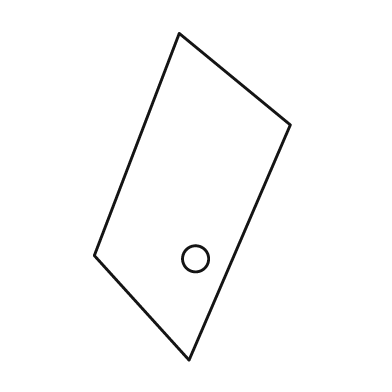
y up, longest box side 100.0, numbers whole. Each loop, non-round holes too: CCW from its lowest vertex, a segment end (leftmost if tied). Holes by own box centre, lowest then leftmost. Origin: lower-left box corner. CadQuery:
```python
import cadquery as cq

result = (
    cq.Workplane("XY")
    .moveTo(29.0, 0.0)
    .lineTo(60.0, 72.0)
    .lineTo(26.0, 100.0)
    .lineTo(0.0, 32.0)
    .close()
    .moveTo(31.0, 31.0)
    .circle(4.0)
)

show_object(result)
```